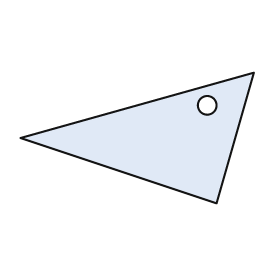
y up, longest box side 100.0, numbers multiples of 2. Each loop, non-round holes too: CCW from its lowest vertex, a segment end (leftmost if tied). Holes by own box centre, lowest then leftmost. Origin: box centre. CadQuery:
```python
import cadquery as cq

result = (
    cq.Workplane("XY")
    .moveTo(34.0, -28.0)
    .lineTo(50.0, 28.0)
    .lineTo(-50.0, 0.0)
    .close()
    .moveTo(30.0, 14.0)
    .circle(4.0)
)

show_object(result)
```